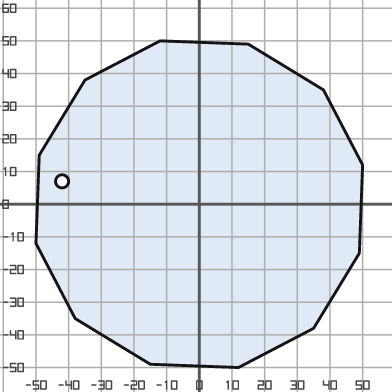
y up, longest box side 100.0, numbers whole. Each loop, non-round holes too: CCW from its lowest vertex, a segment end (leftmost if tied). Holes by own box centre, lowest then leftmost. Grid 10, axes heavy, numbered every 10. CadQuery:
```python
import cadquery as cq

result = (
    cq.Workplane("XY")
    .moveTo(12.0, -50.0)
    .lineTo(35.0, -38.0)
    .lineTo(49.0, -15.0)
    .lineTo(50.0, 12.0)
    .lineTo(38.0, 35.0)
    .lineTo(15.0, 49.0)
    .lineTo(-12.0, 50.0)
    .lineTo(-35.0, 38.0)
    .lineTo(-49.0, 15.0)
    .lineTo(-50.0, -12.0)
    .lineTo(-38.0, -35.0)
    .lineTo(-15.0, -49.0)
    .close()
    .moveTo(-42.0, 7.0)
    .circle(2.0)
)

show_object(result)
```